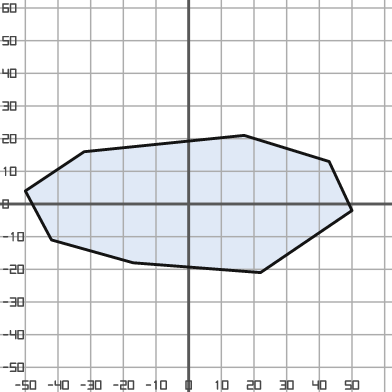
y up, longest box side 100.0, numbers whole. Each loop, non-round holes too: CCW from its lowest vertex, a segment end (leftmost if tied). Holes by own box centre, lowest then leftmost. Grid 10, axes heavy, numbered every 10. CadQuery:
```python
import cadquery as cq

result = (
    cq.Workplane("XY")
    .moveTo(22.0, -21.0)
    .lineTo(50.0, -2.0)
    .lineTo(43.0, 13.0)
    .lineTo(17.0, 21.0)
    .lineTo(-32.0, 16.0)
    .lineTo(-50.0, 4.0)
    .lineTo(-42.0, -11.0)
    .lineTo(-17.0, -18.0)
    .close()
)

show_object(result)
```